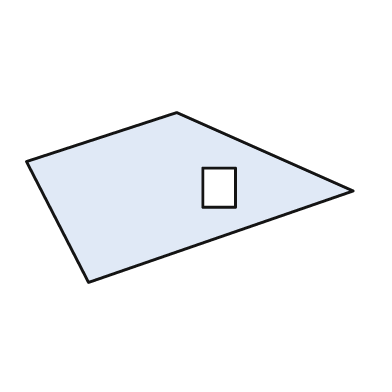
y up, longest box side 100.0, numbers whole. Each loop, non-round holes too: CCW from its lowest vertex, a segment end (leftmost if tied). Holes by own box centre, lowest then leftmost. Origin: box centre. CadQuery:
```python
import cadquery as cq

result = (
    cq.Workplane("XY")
    .moveTo(-31.0, -26.0)
    .lineTo(50.0, 2.0)
    .lineTo(-4.0, 26.0)
    .lineTo(-50.0, 11.0)
    .close()
    .moveTo(4.0, -3.0)
    .lineTo(14.0, -3.0)
    .lineTo(14.0, 9.0)
    .lineTo(4.0, 9.0)
    .close()
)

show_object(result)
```